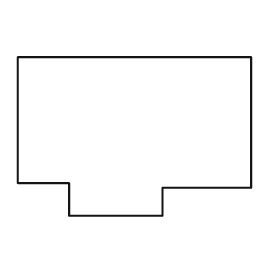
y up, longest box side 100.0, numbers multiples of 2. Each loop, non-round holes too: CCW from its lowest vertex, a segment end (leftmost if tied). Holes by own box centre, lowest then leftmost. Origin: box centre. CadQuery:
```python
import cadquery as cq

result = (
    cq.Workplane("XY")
    .moveTo(-28.0, -34.0)
    .lineTo(12.0, -34.0)
    .lineTo(12.0, -22.0)
    .lineTo(50.0, -22.0)
    .lineTo(50.0, 34.0)
    .lineTo(-50.0, 34.0)
    .lineTo(-50.0, -20.0)
    .lineTo(-28.0, -20.0)
    .close()
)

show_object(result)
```